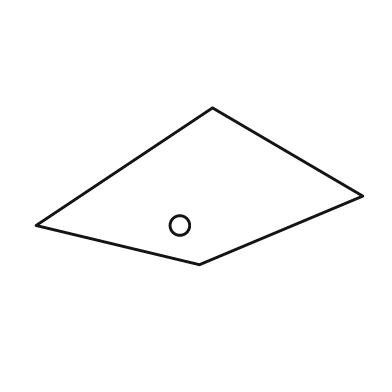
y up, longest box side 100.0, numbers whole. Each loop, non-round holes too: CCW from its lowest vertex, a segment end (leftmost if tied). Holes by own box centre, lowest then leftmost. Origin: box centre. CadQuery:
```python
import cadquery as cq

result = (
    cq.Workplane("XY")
    .moveTo(0.0, -24.0)
    .lineTo(50.0, -3.0)
    .lineTo(4.0, 24.0)
    .lineTo(-50.0, -12.0)
    .close()
    .moveTo(-6.0, -12.0)
    .circle(3.0)
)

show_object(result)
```